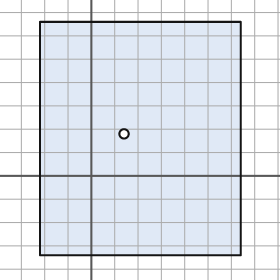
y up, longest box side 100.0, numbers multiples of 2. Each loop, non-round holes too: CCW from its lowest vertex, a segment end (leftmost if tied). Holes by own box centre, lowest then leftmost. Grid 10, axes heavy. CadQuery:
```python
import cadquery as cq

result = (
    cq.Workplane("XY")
    .moveTo(-22.0, -34.0)
    .lineTo(64.0, -34.0)
    .lineTo(64.0, 66.0)
    .lineTo(-22.0, 66.0)
    .close()
    .moveTo(14.0, 18.0)
    .circle(2.0)
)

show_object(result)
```